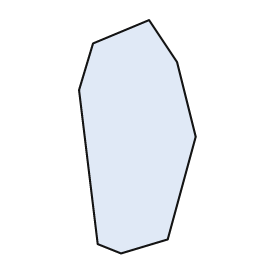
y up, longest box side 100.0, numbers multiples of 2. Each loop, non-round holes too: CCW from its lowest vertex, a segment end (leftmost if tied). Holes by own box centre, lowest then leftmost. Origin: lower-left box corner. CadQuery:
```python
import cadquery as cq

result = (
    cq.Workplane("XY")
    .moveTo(18.0, 0.0)
    .lineTo(38.0, 6.0)
    .lineTo(50.0, 50.0)
    .lineTo(42.0, 82.0)
    .lineTo(30.0, 100.0)
    .lineTo(6.0, 90.0)
    .lineTo(0.0, 70.0)
    .lineTo(8.0, 4.0)
    .close()
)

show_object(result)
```